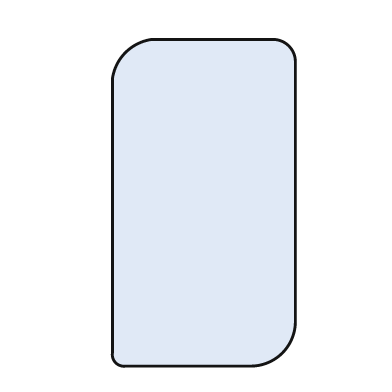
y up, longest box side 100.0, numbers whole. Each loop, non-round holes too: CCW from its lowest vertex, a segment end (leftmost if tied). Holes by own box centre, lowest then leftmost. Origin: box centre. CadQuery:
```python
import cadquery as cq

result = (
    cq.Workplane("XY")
    .moveTo(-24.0, -50.0)
    .lineTo(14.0, -50.0)
    .threePointArc((24.0, -46.0), (28.0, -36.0))
    .lineTo(28.0, 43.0)
    .threePointArc((26.0, 48.0), (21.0, 50.0))
    .lineTo(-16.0, 50.0)
    .threePointArc((-24.0, 46.0), (-28.0, 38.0))
    .lineTo(-28.0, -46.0)
    .threePointArc((-27.0, -49.0), (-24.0, -50.0))
    .close()
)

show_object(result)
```